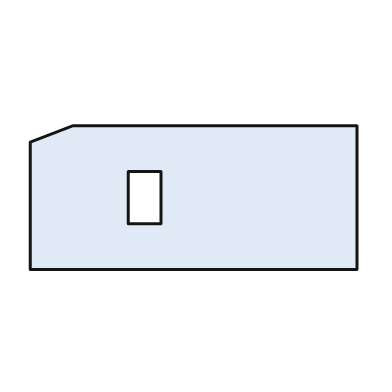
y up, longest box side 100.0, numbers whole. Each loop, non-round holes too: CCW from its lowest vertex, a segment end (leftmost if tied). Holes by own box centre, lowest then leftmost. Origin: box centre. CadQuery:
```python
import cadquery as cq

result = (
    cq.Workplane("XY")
    .moveTo(-50.0, -22.0)
    .lineTo(50.0, -22.0)
    .lineTo(50.0, 22.0)
    .lineTo(-37.0, 22.0)
    .lineTo(-50.0, 17.0)
    .close()
    .moveTo(-20.0, -8.0)
    .lineTo(-10.0, -8.0)
    .lineTo(-10.0, 8.0)
    .lineTo(-20.0, 8.0)
    .close()
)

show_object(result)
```